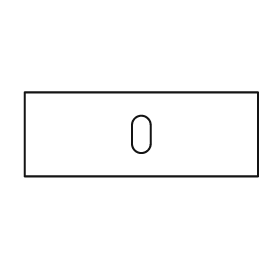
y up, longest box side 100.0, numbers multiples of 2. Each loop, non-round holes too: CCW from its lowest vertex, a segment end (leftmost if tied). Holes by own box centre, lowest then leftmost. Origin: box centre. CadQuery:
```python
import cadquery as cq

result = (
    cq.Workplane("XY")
    .moveTo(-50.0, -18.0)
    .lineTo(50.0, -18.0)
    .lineTo(50.0, 18.0)
    .lineTo(-50.0, 18.0)
    .close()
    .moveTo(-4.0, -4.0)
    .threePointArc((0.0, -8.0), (4.0, -4.0))
    .lineTo(4.0, 4.0)
    .threePointArc((0.0, 8.0), (-4.0, 4.0))
    .close()
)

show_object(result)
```